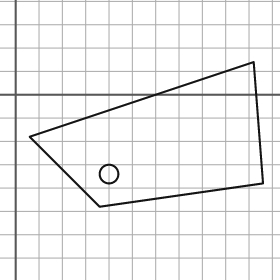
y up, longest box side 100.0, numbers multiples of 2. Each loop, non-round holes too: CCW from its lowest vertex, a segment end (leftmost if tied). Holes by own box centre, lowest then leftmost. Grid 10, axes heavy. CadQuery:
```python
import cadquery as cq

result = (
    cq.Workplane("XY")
    .moveTo(36.0, -48.0)
    .lineTo(106.0, -38.0)
    .lineTo(102.0, 14.0)
    .lineTo(6.0, -18.0)
    .close()
    .moveTo(40.0, -34.0)
    .circle(4.0)
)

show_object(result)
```